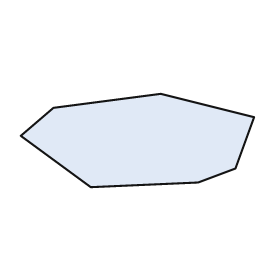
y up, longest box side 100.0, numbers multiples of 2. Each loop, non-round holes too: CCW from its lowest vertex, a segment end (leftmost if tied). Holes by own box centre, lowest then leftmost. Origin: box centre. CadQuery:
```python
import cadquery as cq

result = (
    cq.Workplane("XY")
    .moveTo(-20.0, -20.0)
    .lineTo(26.0, -18.0)
    .lineTo(42.0, -12.0)
    .lineTo(50.0, 10.0)
    .lineTo(10.0, 20.0)
    .lineTo(-36.0, 14.0)
    .lineTo(-50.0, 2.0)
    .close()
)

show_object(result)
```